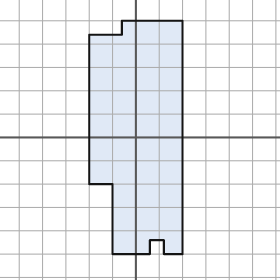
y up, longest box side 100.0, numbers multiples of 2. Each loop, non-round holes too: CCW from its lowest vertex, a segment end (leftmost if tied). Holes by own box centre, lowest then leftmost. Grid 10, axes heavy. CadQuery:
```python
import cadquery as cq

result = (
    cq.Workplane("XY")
    .moveTo(-10.0, -50.0)
    .lineTo(6.0, -50.0)
    .lineTo(6.0, -44.0)
    .lineTo(12.0, -44.0)
    .lineTo(12.0, -50.0)
    .lineTo(20.0, -50.0)
    .lineTo(20.0, 50.0)
    .lineTo(-6.0, 50.0)
    .lineTo(-6.0, 44.0)
    .lineTo(-20.0, 44.0)
    .lineTo(-20.0, -20.0)
    .lineTo(-10.0, -20.0)
    .close()
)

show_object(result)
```